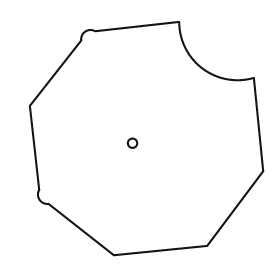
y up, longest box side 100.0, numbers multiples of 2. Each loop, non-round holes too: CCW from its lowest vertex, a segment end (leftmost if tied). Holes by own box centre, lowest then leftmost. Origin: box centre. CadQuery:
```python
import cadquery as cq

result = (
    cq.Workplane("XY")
    .moveTo(-14.0, -50.0)
    .lineTo(26.0, -46.0)
    .lineTo(50.0, -14.0)
    .lineTo(46.0, 26.0)
    .threePointArc((24.0, 30.0), (14.0, 50.0))
    .lineTo(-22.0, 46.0)
    .threePointArc((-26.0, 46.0), (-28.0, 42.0))
    .lineTo(-50.0, 14.0)
    .lineTo(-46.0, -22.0)
    .threePointArc((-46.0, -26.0), (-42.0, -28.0))
    .close()
    .moveTo(-6.0, -2.0)
    .circle(2.0)
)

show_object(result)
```